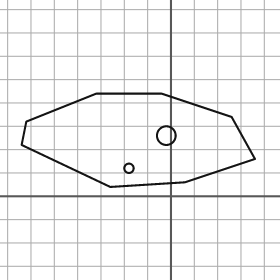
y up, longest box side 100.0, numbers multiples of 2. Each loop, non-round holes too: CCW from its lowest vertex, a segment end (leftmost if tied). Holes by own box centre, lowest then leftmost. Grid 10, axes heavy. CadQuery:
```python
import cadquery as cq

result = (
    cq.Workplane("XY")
    .moveTo(-26.0, 4.0)
    .lineTo(6.0, 6.0)
    .lineTo(36.0, 16.0)
    .lineTo(26.0, 34.0)
    .lineTo(-4.0, 44.0)
    .lineTo(-32.0, 44.0)
    .lineTo(-62.0, 32.0)
    .lineTo(-64.0, 22.0)
    .close()
    .moveTo(-18.0, 12.0)
    .circle(2.0)
    .moveTo(-2.0, 26.0)
    .circle(4.0)
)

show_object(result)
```